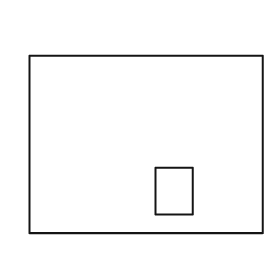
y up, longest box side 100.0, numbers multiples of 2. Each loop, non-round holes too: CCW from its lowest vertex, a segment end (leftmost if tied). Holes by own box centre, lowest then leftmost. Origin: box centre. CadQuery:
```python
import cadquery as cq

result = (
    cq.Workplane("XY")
    .moveTo(-50.0, -38.0)
    .lineTo(50.0, -38.0)
    .lineTo(50.0, 38.0)
    .lineTo(-50.0, 38.0)
    .close()
    .moveTo(4.0, -30.0)
    .lineTo(20.0, -30.0)
    .lineTo(20.0, -10.0)
    .lineTo(4.0, -10.0)
    .close()
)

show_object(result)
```